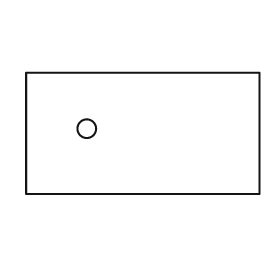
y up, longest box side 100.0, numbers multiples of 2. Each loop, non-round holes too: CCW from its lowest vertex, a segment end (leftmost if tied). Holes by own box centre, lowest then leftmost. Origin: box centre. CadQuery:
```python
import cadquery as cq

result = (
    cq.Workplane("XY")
    .moveTo(-50.0, -26.0)
    .lineTo(50.0, -26.0)
    .lineTo(50.0, 26.0)
    .lineTo(-50.0, 26.0)
    .close()
    .moveTo(-24.0, 2.0)
    .circle(4.0)
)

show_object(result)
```